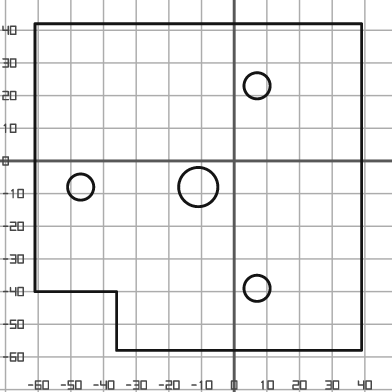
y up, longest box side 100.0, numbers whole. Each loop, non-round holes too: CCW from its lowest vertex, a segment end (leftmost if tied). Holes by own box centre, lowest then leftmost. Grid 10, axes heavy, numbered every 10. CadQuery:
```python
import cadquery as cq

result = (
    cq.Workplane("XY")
    .moveTo(-36.0, -58.0)
    .lineTo(39.0, -58.0)
    .lineTo(39.0, 42.0)
    .lineTo(-61.0, 42.0)
    .lineTo(-61.0, -40.0)
    .lineTo(-36.0, -40.0)
    .close()
    .moveTo(7.0, -39.0)
    .circle(4.0)
    .moveTo(-47.0, -8.0)
    .circle(4.0)
    .moveTo(-11.0, -8.0)
    .circle(6.0)
    .moveTo(7.0, 23.0)
    .circle(4.0)
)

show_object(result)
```